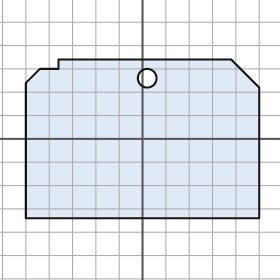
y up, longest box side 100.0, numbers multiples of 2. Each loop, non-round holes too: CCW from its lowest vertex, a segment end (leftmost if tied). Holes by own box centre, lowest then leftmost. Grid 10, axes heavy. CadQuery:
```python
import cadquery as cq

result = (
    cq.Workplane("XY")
    .moveTo(-50.0, -34.0)
    .lineTo(50.0, -34.0)
    .lineTo(50.0, 22.0)
    .lineTo(38.0, 34.0)
    .lineTo(-36.0, 34.0)
    .lineTo(-36.0, 30.0)
    .lineTo(-44.0, 30.0)
    .lineTo(-50.0, 24.0)
    .close()
    .moveTo(2.0, 26.0)
    .circle(4.0)
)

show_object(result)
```